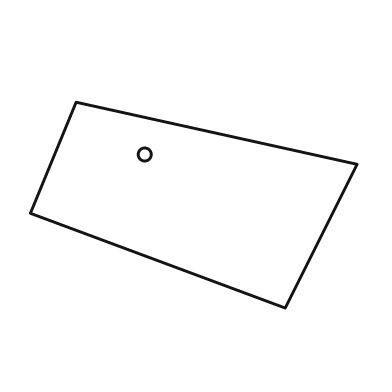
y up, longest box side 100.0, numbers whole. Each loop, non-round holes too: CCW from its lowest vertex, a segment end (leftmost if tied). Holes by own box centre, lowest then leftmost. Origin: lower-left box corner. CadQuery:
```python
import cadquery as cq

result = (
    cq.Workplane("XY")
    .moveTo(78.0, 0.0)
    .lineTo(100.0, 44.0)
    .lineTo(14.0, 63.0)
    .lineTo(0.0, 29.0)
    .close()
    .moveTo(35.0, 47.0)
    .circle(2.0)
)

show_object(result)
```